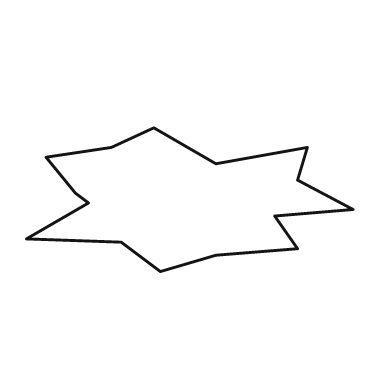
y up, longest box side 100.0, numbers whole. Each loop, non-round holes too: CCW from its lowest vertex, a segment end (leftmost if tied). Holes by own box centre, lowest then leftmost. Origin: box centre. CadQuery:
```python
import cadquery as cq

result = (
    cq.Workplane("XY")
    .moveTo(-9.0, -22.0)
    .lineTo(8.0, -17.0)
    .lineTo(33.0, -15.0)
    .lineTo(26.0, -5.0)
    .lineTo(50.0, -3.0)
    .lineTo(33.0, 6.0)
    .lineTo(36.0, 16.0)
    .lineTo(8.0, 11.0)
    .lineTo(-11.0, 22.0)
    .lineTo(-24.0, 16.0)
    .lineTo(-44.0, 13.0)
    .lineTo(-35.0, 2.0)
    .lineTo(-31.0, -1.0)
    .lineTo(-50.0, -12.0)
    .lineTo(-21.0, -13.0)
    .close()
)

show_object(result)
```